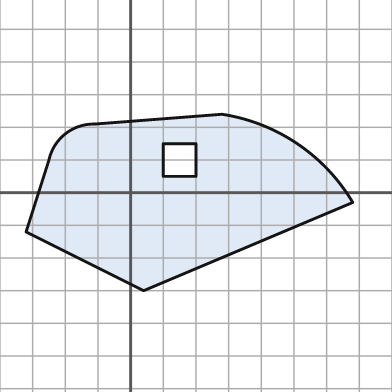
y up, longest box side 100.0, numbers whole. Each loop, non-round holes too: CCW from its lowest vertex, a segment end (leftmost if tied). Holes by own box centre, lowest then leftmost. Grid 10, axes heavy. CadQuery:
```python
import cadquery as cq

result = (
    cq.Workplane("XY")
    .moveTo(4.0, -30.0)
    .lineTo(68.0, -3.0)
    .threePointArc((51.0, 15.0), (28.0, 24.0))
    .lineTo(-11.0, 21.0)
    .threePointArc((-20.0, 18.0), (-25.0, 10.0))
    .lineTo(-32.0, -12.0)
    .close()
    .moveTo(10.0, 5.0)
    .lineTo(20.0, 5.0)
    .lineTo(20.0, 15.0)
    .lineTo(10.0, 15.0)
    .close()
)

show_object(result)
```